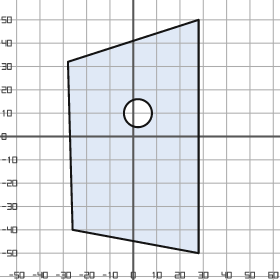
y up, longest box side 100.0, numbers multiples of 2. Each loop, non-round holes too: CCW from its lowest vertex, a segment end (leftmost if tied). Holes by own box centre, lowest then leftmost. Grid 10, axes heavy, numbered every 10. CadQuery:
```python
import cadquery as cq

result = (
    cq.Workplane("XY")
    .moveTo(28.0, -50.0)
    .lineTo(28.0, 50.0)
    .lineTo(-28.0, 32.0)
    .lineTo(-26.0, -40.0)
    .close()
    .moveTo(2.0, 10.0)
    .circle(6.0)
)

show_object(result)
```